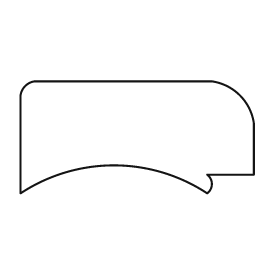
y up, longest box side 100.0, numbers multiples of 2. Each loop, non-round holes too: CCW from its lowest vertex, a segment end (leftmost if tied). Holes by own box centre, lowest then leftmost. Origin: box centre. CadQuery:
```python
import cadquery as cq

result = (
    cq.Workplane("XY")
    .moveTo(-50.0, -24.0)
    .threePointArc((-10.0, -12.0), (30.0, -24.0))
    .threePointArc((32.0, -20.0), (30.0, -16.0))
    .lineTo(50.0, -16.0)
    .lineTo(50.0, 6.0)
    .threePointArc((44.0, 18.0), (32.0, 24.0))
    .lineTo(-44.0, 24.0)
    .threePointArc((-48.0, 22.0), (-50.0, 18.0))
    .close()
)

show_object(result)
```